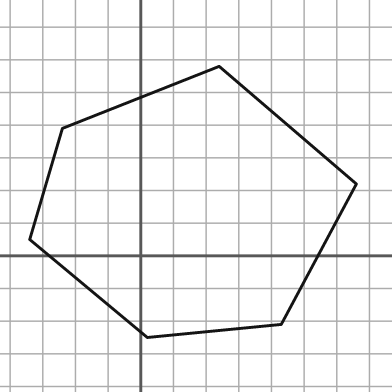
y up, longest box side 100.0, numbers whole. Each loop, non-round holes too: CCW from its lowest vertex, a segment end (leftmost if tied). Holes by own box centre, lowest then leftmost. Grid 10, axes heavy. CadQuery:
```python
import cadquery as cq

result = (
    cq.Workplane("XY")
    .moveTo(2.0, -25.0)
    .lineTo(43.0, -21.0)
    .lineTo(66.0, 22.0)
    .lineTo(24.0, 58.0)
    .lineTo(-24.0, 39.0)
    .lineTo(-34.0, 5.0)
    .close()
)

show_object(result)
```